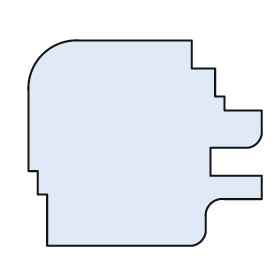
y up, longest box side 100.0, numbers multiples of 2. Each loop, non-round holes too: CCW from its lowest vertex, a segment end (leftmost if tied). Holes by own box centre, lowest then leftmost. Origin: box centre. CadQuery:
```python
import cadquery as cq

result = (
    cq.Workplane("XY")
    .moveTo(-42.0, -44.0)
    .lineTo(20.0, -44.0)
    .threePointArc((24.0, -42.0), (26.0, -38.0))
    .lineTo(26.0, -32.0)
    .threePointArc((28.0, -26.0), (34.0, -24.0))
    .lineTo(50.0, -24.0)
    .lineTo(50.0, -14.0)
    .lineTo(28.0, -14.0)
    .lineTo(28.0, -2.0)
    .lineTo(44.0, -2.0)
    .threePointArc((48.0, 0.0), (50.0, 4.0))
    .lineTo(50.0, 14.0)
    .lineTo(34.0, 14.0)
    .lineTo(34.0, 20.0)
    .lineTo(30.0, 20.0)
    .lineTo(30.0, 32.0)
    .lineTo(20.0, 32.0)
    .lineTo(20.0, 44.0)
    .lineTo(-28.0, 44.0)
    .threePointArc((-44.0, 38.0), (-50.0, 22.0))
    .lineTo(-50.0, -12.0)
    .lineTo(-46.0, -12.0)
    .lineTo(-46.0, -22.0)
    .lineTo(-42.0, -22.0)
    .close()
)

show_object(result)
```